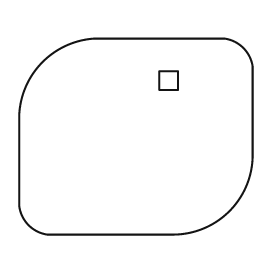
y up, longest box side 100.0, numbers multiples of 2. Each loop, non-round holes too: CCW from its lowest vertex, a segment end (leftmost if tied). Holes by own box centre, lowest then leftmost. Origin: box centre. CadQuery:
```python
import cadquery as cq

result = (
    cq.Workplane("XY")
    .moveTo(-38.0, -42.0)
    .lineTo(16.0, -42.0)
    .threePointArc((40.0, -32.0), (50.0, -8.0))
    .lineTo(50.0, 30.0)
    .threePointArc((46.0, 38.0), (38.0, 42.0))
    .lineTo(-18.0, 42.0)
    .threePointArc((-40.0, 32.0), (-50.0, 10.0))
    .lineTo(-50.0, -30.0)
    .threePointArc((-46.0, -38.0), (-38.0, -42.0))
    .close()
    .moveTo(10.0, 20.0)
    .lineTo(18.0, 20.0)
    .lineTo(18.0, 28.0)
    .lineTo(10.0, 28.0)
    .close()
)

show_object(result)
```